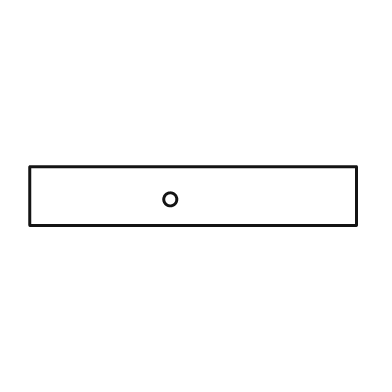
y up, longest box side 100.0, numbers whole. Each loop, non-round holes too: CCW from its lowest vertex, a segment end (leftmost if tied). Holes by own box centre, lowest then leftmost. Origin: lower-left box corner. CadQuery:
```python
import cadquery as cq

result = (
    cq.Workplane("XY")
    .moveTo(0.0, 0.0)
    .lineTo(100.0, 0.0)
    .lineTo(100.0, 18.0)
    .lineTo(0.0, 18.0)
    .close()
    .moveTo(43.0, 8.0)
    .circle(2.0)
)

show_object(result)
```